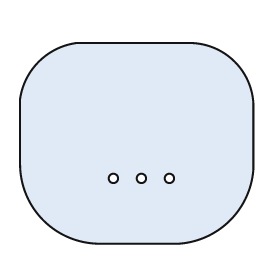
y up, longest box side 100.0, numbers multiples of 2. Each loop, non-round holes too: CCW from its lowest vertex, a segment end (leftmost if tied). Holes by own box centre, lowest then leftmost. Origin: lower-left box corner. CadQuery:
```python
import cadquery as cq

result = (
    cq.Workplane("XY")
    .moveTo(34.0, 0.0)
    .lineTo(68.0, 0.0)
    .threePointArc((90.0, 10.0), (100.0, 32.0))
    .lineTo(100.0, 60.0)
    .threePointArc((92.0, 78.0), (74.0, 86.0))
    .lineTo(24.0, 86.0)
    .threePointArc((8.0, 78.0), (0.0, 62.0))
    .lineTo(0.0, 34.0)
    .threePointArc((10.0, 10.0), (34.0, 0.0))
    .close()
    .moveTo(40.0, 28.0)
    .circle(2.0)
    .moveTo(52.0, 28.0)
    .circle(2.0)
    .moveTo(64.0, 28.0)
    .circle(2.0)
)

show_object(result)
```